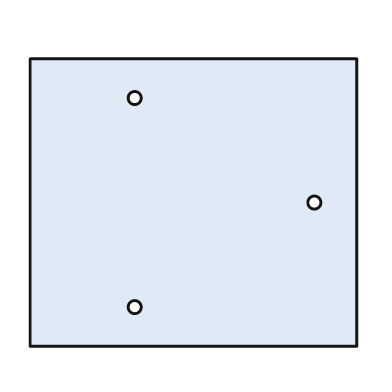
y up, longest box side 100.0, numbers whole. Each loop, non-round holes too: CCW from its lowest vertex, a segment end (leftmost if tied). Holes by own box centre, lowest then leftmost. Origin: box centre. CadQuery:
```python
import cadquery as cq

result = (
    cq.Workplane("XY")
    .moveTo(-50.0, -44.0)
    .lineTo(50.0, -44.0)
    .lineTo(50.0, 44.0)
    .lineTo(-50.0, 44.0)
    .close()
    .moveTo(-18.0, -32.0)
    .circle(2.0)
    .moveTo(37.0, 0.0)
    .circle(2.0)
    .moveTo(-18.0, 32.0)
    .circle(2.0)
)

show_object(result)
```